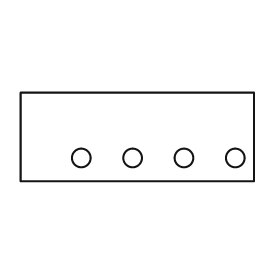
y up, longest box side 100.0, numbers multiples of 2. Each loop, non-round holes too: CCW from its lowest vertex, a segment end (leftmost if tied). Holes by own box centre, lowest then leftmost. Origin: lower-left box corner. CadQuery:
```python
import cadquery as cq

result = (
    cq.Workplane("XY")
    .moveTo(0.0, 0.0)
    .lineTo(100.0, 0.0)
    .lineTo(100.0, 38.0)
    .lineTo(0.0, 38.0)
    .close()
    .moveTo(26.0, 10.0)
    .circle(4.0)
    .moveTo(48.0, 10.0)
    .circle(4.0)
    .moveTo(70.0, 10.0)
    .circle(4.0)
    .moveTo(92.0, 10.0)
    .circle(4.0)
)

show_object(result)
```